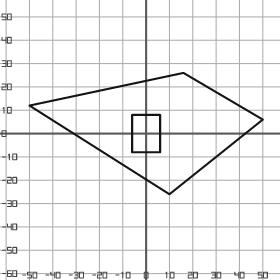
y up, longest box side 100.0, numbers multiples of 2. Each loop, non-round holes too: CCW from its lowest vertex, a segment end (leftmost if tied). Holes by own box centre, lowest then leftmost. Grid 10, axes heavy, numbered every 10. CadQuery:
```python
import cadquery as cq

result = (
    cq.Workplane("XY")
    .moveTo(10.0, -26.0)
    .lineTo(50.0, 6.0)
    .lineTo(16.0, 26.0)
    .lineTo(-50.0, 12.0)
    .close()
    .moveTo(-6.0, -8.0)
    .lineTo(6.0, -8.0)
    .lineTo(6.0, 8.0)
    .lineTo(-6.0, 8.0)
    .close()
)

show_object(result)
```